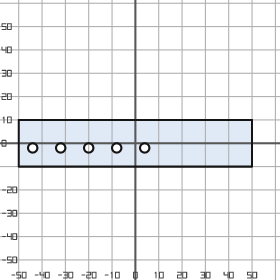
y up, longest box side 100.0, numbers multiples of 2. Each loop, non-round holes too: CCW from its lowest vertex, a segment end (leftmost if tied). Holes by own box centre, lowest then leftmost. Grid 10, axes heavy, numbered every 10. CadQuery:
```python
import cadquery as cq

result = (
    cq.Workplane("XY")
    .moveTo(-50.0, -10.0)
    .lineTo(50.0, -10.0)
    .lineTo(50.0, 10.0)
    .lineTo(-50.0, 10.0)
    .close()
    .moveTo(-44.0, -2.0)
    .circle(2.0)
    .moveTo(-32.0, -2.0)
    .circle(2.0)
    .moveTo(-20.0, -2.0)
    .circle(2.0)
    .moveTo(-8.0, -2.0)
    .circle(2.0)
    .moveTo(4.0, -2.0)
    .circle(2.0)
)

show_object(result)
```